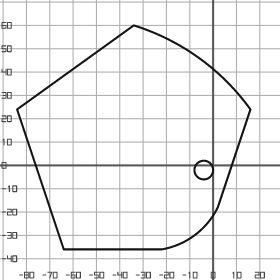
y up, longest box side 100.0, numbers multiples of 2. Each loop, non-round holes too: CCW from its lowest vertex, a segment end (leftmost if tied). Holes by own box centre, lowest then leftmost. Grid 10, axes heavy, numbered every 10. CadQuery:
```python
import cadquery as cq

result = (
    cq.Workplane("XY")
    .moveTo(-64.0, -36.0)
    .lineTo(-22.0, -36.0)
    .threePointArc((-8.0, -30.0), (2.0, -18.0))
    .lineTo(16.0, 24.0)
    .threePointArc((-6.0, 46.0), (-34.0, 60.0))
    .lineTo(-84.0, 24.0)
    .close()
    .moveTo(-4.0, -2.0)
    .circle(4.0)
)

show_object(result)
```